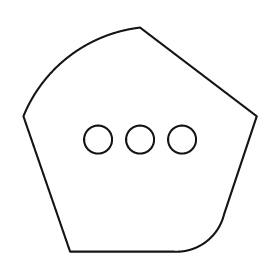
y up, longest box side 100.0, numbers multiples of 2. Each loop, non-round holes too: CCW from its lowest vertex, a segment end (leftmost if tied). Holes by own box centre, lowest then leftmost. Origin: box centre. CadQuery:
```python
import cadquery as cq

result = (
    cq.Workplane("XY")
    .moveTo(-30.0, -48.0)
    .lineTo(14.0, -48.0)
    .threePointArc((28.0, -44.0), (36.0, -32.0))
    .lineTo(50.0, 10.0)
    .lineTo(0.0, 48.0)
    .threePointArc((-30.0, 36.0), (-50.0, 10.0))
    .close()
    .moveTo(-18.0, 0.0)
    .circle(6.0)
    .moveTo(0.0, 0.0)
    .circle(6.0)
    .moveTo(18.0, 0.0)
    .circle(6.0)
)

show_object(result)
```